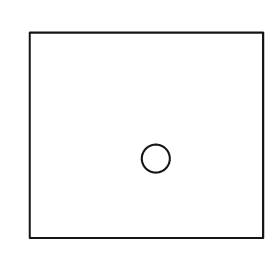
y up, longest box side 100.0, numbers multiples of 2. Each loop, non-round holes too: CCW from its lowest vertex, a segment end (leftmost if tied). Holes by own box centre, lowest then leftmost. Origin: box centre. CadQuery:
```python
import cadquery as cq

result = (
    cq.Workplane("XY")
    .moveTo(-50.0, -44.0)
    .lineTo(50.0, -44.0)
    .lineTo(50.0, 44.0)
    .lineTo(-50.0, 44.0)
    .close()
    .moveTo(4.0, -10.0)
    .circle(6.0)
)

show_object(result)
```